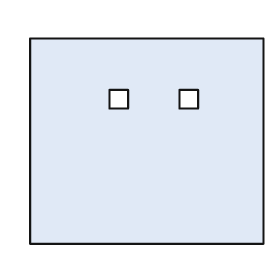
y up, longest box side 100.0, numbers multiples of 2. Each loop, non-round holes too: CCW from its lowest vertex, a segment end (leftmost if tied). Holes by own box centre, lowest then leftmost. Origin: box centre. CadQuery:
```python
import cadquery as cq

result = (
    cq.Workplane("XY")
    .moveTo(-50.0, -44.0)
    .lineTo(50.0, -44.0)
    .lineTo(50.0, 44.0)
    .lineTo(-50.0, 44.0)
    .close()
    .moveTo(-16.0, 14.0)
    .lineTo(-8.0, 14.0)
    .lineTo(-8.0, 22.0)
    .lineTo(-16.0, 22.0)
    .close()
    .moveTo(14.0, 14.0)
    .lineTo(22.0, 14.0)
    .lineTo(22.0, 22.0)
    .lineTo(14.0, 22.0)
    .close()
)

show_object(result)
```